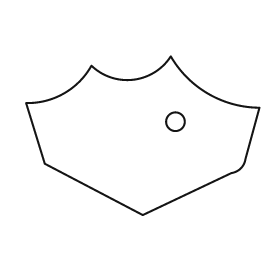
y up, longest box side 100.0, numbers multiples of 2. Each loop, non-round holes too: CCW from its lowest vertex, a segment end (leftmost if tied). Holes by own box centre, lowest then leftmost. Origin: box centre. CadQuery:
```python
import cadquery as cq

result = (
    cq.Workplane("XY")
    .moveTo(0.0, -34.0)
    .lineTo(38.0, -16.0)
    .threePointArc((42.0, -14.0), (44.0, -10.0))
    .lineTo(50.0, 12.0)
    .threePointArc((28.0, 18.0), (12.0, 34.0))
    .threePointArc((-4.0, 24.0), (-22.0, 30.0))
    .threePointArc((-34.0, 18.0), (-50.0, 14.0))
    .lineTo(-42.0, -12.0)
    .close()
    .moveTo(14.0, 6.0)
    .circle(4.0)
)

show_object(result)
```